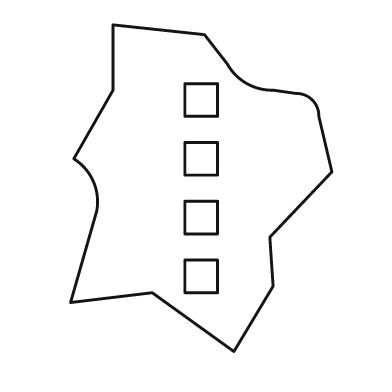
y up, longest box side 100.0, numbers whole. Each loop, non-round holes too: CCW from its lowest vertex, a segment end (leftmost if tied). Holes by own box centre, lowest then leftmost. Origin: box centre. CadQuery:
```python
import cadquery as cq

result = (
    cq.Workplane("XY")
    .moveTo(10.0, -50.0)
    .lineTo(22.0, -30.0)
    .lineTo(21.0, -15.0)
    .lineTo(40.0, 5.0)
    .lineTo(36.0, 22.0)
    .threePointArc((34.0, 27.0), (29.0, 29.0))
    .lineTo(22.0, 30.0)
    .threePointArc((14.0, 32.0), (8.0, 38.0))
    .lineTo(1.0, 47.0)
    .lineTo(-27.0, 50.0)
    .lineTo(-27.0, 30.0)
    .lineTo(-39.0, 9.0)
    .threePointArc((-33.0, 2.0), (-32.0, -7.0))
    .lineTo(-40.0, -35.0)
    .lineTo(-15.0, -32.0)
    .close()
    .moveTo(-5.0, -32.0)
    .lineTo(5.0, -32.0)
    .lineTo(5.0, -22.0)
    .lineTo(-5.0, -22.0)
    .close()
    .moveTo(-5.0, -14.0)
    .lineTo(5.0, -14.0)
    .lineTo(5.0, -4.0)
    .lineTo(-5.0, -4.0)
    .close()
    .moveTo(-5.0, 4.0)
    .lineTo(5.0, 4.0)
    .lineTo(5.0, 14.0)
    .lineTo(-5.0, 14.0)
    .close()
    .moveTo(-5.0, 22.0)
    .lineTo(5.0, 22.0)
    .lineTo(5.0, 32.0)
    .lineTo(-5.0, 32.0)
    .close()
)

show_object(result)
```